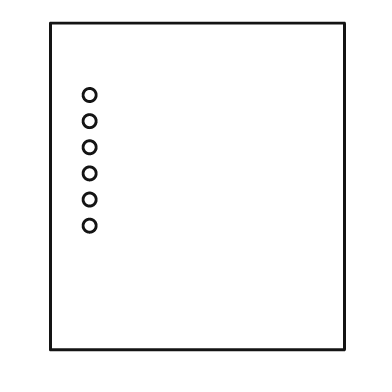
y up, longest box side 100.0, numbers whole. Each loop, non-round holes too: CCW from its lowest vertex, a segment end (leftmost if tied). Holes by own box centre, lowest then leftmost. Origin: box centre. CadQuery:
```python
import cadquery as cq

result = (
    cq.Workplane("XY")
    .moveTo(-45.0, -50.0)
    .lineTo(45.0, -50.0)
    .lineTo(45.0, 50.0)
    .lineTo(-45.0, 50.0)
    .close()
    .moveTo(-33.0, -12.0)
    .circle(2.0)
    .moveTo(-33.0, -4.0)
    .circle(2.0)
    .moveTo(-33.0, 4.0)
    .circle(2.0)
    .moveTo(-33.0, 12.0)
    .circle(2.0)
    .moveTo(-33.0, 20.0)
    .circle(2.0)
    .moveTo(-33.0, 28.0)
    .circle(2.0)
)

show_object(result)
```